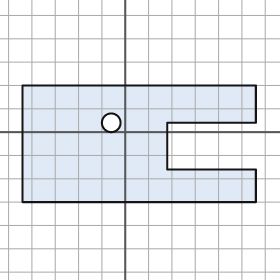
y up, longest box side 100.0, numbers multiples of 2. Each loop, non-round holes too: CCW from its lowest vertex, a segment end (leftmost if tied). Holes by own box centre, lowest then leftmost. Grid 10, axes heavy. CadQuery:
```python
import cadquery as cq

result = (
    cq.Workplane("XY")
    .moveTo(-44.0, -30.0)
    .lineTo(56.0, -30.0)
    .lineTo(56.0, -16.0)
    .lineTo(18.0, -16.0)
    .lineTo(18.0, 4.0)
    .lineTo(56.0, 4.0)
    .lineTo(56.0, 20.0)
    .lineTo(-44.0, 20.0)
    .close()
    .moveTo(-6.0, 4.0)
    .circle(4.0)
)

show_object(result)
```